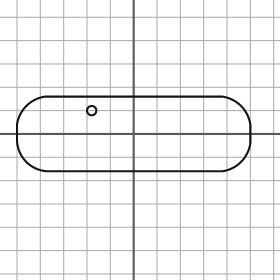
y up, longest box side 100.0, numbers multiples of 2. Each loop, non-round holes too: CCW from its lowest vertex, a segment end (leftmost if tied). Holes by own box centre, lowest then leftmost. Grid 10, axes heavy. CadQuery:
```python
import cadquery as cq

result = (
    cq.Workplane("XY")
    .moveTo(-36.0, -16.0)
    .lineTo(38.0, -16.0)
    .threePointArc((46.0, -12.0), (50.0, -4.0))
    .lineTo(50.0, 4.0)
    .threePointArc((46.0, 12.0), (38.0, 16.0))
    .lineTo(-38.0, 16.0)
    .threePointArc((-46.0, 12.0), (-50.0, 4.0))
    .lineTo(-50.0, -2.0)
    .threePointArc((-46.0, -12.0), (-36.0, -16.0))
    .close()
    .moveTo(-18.0, 10.0)
    .circle(2.0)
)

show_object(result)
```